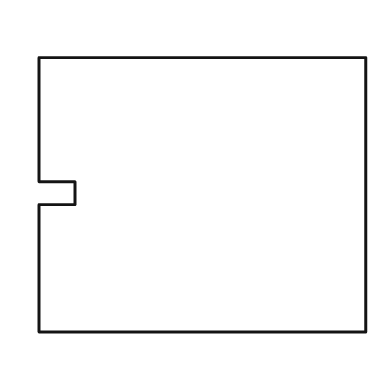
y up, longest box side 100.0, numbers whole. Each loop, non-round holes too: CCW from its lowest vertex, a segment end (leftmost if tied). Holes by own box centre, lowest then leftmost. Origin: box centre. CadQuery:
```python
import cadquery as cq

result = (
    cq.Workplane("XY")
    .moveTo(-50.0, -42.0)
    .lineTo(50.0, -42.0)
    .lineTo(50.0, 42.0)
    .lineTo(-50.0, 42.0)
    .lineTo(-50.0, 4.0)
    .lineTo(-39.0, 4.0)
    .lineTo(-39.0, -3.0)
    .lineTo(-50.0, -3.0)
    .close()
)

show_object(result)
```